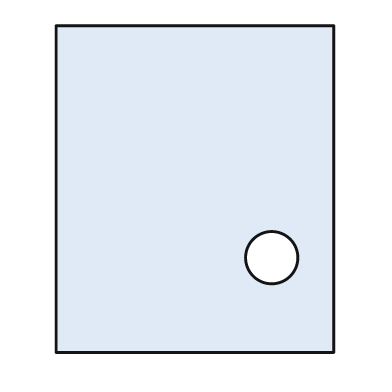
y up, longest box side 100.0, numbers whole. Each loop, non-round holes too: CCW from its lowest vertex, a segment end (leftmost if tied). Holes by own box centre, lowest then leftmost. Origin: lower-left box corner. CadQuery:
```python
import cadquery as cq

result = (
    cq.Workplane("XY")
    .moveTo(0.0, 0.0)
    .lineTo(85.0, 0.0)
    .lineTo(85.0, 100.0)
    .lineTo(0.0, 100.0)
    .close()
    .moveTo(66.0, 29.0)
    .circle(8.0)
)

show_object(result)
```